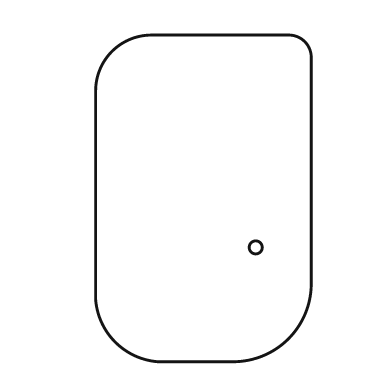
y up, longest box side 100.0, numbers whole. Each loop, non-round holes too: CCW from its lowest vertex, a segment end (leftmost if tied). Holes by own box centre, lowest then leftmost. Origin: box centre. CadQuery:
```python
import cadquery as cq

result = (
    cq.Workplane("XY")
    .moveTo(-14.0, -50.0)
    .lineTo(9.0, -50.0)
    .threePointArc((26.0, -43.0), (33.0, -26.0))
    .lineTo(33.0, 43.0)
    .threePointArc((31.0, 48.0), (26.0, 50.0))
    .lineTo(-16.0, 50.0)
    .threePointArc((-28.0, 45.0), (-33.0, 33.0))
    .lineTo(-33.0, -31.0)
    .threePointArc((-27.0, -44.0), (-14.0, -50.0))
    .close()
    .moveTo(16.0, -15.0)
    .circle(2.0)
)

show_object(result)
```